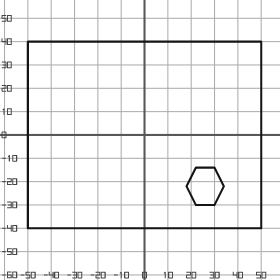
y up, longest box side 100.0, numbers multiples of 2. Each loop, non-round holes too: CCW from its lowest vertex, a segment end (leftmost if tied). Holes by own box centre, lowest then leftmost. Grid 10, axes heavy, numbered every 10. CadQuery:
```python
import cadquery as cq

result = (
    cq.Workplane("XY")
    .moveTo(-50.0, -40.0)
    .lineTo(50.0, -40.0)
    .lineTo(50.0, 40.0)
    .lineTo(-50.0, 40.0)
    .close()
    .moveTo(22.0, -30.0)
    .lineTo(30.0, -30.0)
    .lineTo(34.0, -22.0)
    .lineTo(30.0, -14.0)
    .lineTo(22.0, -14.0)
    .lineTo(18.0, -22.0)
    .close()
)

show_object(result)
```